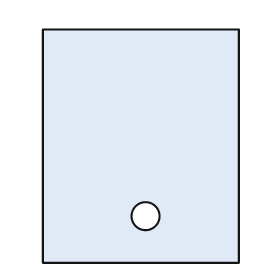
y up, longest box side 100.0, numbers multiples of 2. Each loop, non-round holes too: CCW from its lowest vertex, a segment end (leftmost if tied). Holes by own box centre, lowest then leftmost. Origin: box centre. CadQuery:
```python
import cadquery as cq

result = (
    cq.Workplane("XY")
    .moveTo(-42.0, -50.0)
    .lineTo(42.0, -50.0)
    .lineTo(42.0, 50.0)
    .lineTo(-42.0, 50.0)
    .close()
    .moveTo(2.0, -30.0)
    .circle(6.0)
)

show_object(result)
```